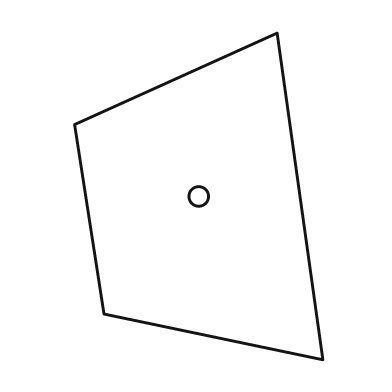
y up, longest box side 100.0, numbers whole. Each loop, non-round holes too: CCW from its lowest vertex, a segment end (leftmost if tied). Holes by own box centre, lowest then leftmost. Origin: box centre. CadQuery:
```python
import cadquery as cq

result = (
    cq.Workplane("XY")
    .moveTo(38.0, -50.0)
    .lineTo(24.0, 50.0)
    .lineTo(-38.0, 22.0)
    .lineTo(-29.0, -36.0)
    .close()
    .moveTo(0.0, 0.0)
    .circle(3.0)
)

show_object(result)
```